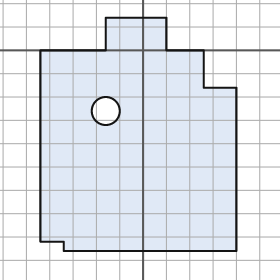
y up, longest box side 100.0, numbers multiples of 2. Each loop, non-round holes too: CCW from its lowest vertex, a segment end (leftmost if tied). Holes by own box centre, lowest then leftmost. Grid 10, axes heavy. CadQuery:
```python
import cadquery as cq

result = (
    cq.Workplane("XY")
    .moveTo(-34.0, -86.0)
    .lineTo(40.0, -86.0)
    .lineTo(40.0, -16.0)
    .lineTo(26.0, -16.0)
    .lineTo(26.0, 0.0)
    .lineTo(10.0, 0.0)
    .lineTo(10.0, 14.0)
    .lineTo(-16.0, 14.0)
    .lineTo(-16.0, 0.0)
    .lineTo(-44.0, 0.0)
    .lineTo(-44.0, -82.0)
    .lineTo(-34.0, -82.0)
    .close()
    .moveTo(-16.0, -26.0)
    .circle(6.0)
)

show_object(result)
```